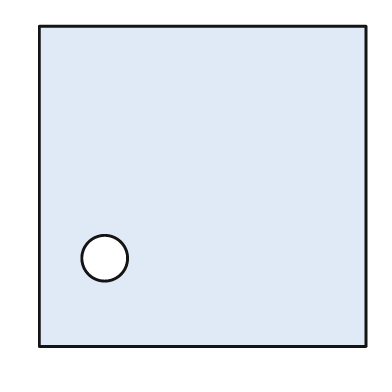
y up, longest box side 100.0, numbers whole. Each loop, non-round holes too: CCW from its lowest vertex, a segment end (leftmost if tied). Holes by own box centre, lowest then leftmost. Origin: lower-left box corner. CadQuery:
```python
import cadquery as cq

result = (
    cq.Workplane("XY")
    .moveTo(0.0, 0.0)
    .lineTo(100.0, 0.0)
    .lineTo(100.0, 98.0)
    .lineTo(0.0, 98.0)
    .close()
    .moveTo(20.0, 27.0)
    .circle(7.0)
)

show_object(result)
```